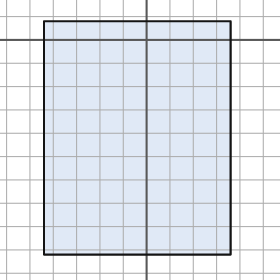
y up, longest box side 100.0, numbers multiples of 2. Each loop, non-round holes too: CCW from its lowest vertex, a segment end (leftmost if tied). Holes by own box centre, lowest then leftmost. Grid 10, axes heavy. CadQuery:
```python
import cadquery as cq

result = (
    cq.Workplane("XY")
    .moveTo(-44.0, -92.0)
    .lineTo(36.0, -92.0)
    .lineTo(36.0, 8.0)
    .lineTo(-44.0, 8.0)
    .close()
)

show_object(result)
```